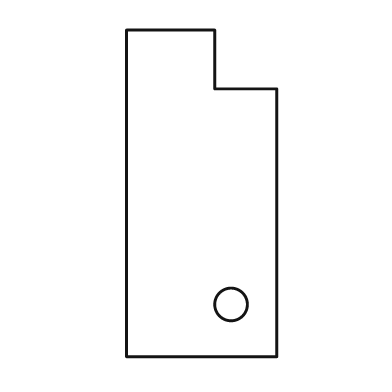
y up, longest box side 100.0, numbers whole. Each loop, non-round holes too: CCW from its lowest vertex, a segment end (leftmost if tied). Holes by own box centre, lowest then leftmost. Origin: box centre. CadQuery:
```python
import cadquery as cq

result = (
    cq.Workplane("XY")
    .moveTo(-23.0, -50.0)
    .lineTo(23.0, -50.0)
    .lineTo(23.0, 32.0)
    .lineTo(4.0, 32.0)
    .lineTo(4.0, 50.0)
    .lineTo(-23.0, 50.0)
    .close()
    .moveTo(9.0, -34.0)
    .circle(5.0)
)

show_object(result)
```